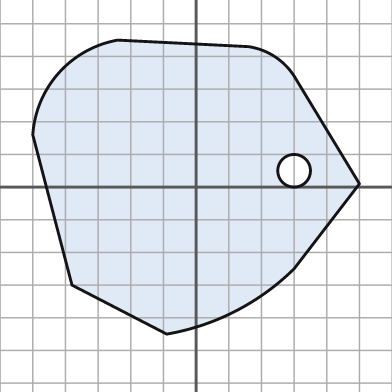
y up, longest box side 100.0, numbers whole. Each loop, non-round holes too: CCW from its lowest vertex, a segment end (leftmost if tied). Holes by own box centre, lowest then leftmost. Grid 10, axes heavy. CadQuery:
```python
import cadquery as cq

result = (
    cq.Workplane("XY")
    .moveTo(-9.0, -45.0)
    .threePointArc((12.0, -38.0), (30.0, -25.0))
    .lineTo(50.0, 1.0)
    .lineTo(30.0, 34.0)
    .threePointArc((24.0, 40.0), (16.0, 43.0))
    .lineTo(-24.0, 45.0)
    .threePointArc((-42.0, 35.0), (-50.0, 16.0))
    .lineTo(-38.0, -30.0)
    .close()
    .moveTo(30.0, 5.0)
    .circle(5.0)
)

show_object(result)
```